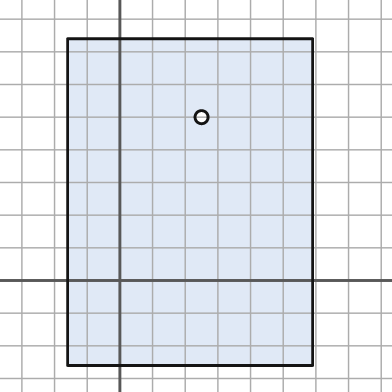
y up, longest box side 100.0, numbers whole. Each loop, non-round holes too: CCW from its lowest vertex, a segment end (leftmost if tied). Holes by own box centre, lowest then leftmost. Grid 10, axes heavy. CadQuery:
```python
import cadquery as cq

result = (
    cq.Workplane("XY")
    .moveTo(-16.0, -26.0)
    .lineTo(59.0, -26.0)
    .lineTo(59.0, 74.0)
    .lineTo(-16.0, 74.0)
    .close()
    .moveTo(25.0, 50.0)
    .circle(2.0)
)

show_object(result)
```